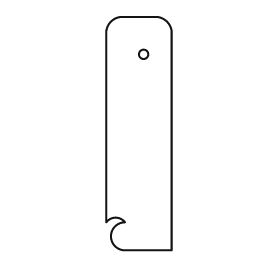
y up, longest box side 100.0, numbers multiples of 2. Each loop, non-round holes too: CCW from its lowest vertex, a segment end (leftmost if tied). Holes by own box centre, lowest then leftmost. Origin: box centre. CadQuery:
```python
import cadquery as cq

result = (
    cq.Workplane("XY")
    .moveTo(-6.0, -50.0)
    .lineTo(14.0, -50.0)
    .lineTo(14.0, 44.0)
    .threePointArc((12.0, 48.0), (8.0, 50.0))
    .lineTo(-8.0, 50.0)
    .threePointArc((-12.0, 48.0), (-14.0, 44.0))
    .lineTo(-14.0, -38.0)
    .threePointArc((-10.0, -36.0), (-6.0, -38.0))
    .threePointArc((-12.0, -44.0), (-6.0, -50.0))
    .close()
    .moveTo(2.0, 34.0)
    .circle(2.0)
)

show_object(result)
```